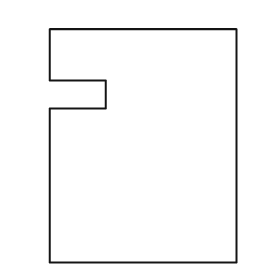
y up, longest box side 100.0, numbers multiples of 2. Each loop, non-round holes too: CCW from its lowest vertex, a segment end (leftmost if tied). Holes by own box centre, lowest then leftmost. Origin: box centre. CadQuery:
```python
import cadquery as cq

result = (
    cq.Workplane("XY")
    .moveTo(-40.0, -50.0)
    .lineTo(40.0, -50.0)
    .lineTo(40.0, 50.0)
    .lineTo(-40.0, 50.0)
    .lineTo(-40.0, 28.0)
    .lineTo(-16.0, 28.0)
    .lineTo(-16.0, 16.0)
    .lineTo(-40.0, 16.0)
    .close()
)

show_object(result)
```